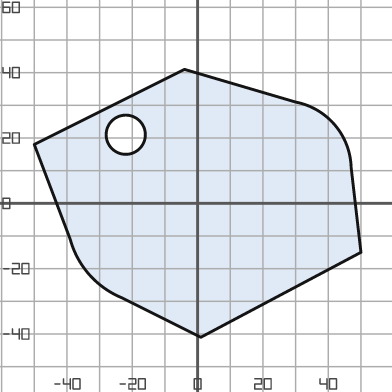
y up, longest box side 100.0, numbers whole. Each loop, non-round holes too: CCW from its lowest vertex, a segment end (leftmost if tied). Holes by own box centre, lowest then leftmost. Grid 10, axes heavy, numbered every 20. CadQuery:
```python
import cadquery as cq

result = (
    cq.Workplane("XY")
    .moveTo(1.0, -41.0)
    .lineTo(50.0, -15.0)
    .lineTo(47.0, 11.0)
    .threePointArc((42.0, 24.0), (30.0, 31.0))
    .lineTo(-4.0, 41.0)
    .lineTo(-50.0, 18.0)
    .lineTo(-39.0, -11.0)
    .threePointArc((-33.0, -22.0), (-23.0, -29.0))
    .close()
    .moveTo(-22.0, 21.0)
    .circle(6.0)
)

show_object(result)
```